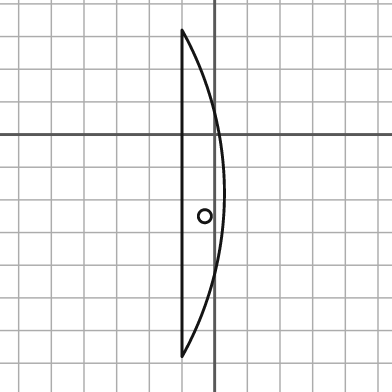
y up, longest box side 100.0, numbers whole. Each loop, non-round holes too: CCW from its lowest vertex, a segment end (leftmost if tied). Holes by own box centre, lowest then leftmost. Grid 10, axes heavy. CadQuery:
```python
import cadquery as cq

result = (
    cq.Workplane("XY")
    .moveTo(-10.0, -68.0)
    .threePointArc((3.0, -18.0), (-10.0, 32.0))
    .close()
    .moveTo(-3.0, -25.0)
    .circle(2.0)
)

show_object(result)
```